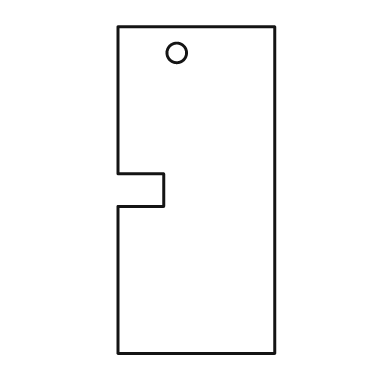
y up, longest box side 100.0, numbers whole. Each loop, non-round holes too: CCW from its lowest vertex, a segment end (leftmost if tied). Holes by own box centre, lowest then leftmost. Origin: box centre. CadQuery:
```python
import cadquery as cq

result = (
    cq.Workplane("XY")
    .moveTo(-24.0, -50.0)
    .lineTo(24.0, -50.0)
    .lineTo(24.0, 50.0)
    .lineTo(-24.0, 50.0)
    .lineTo(-24.0, 5.0)
    .lineTo(-10.0, 5.0)
    .lineTo(-10.0, -5.0)
    .lineTo(-24.0, -5.0)
    .close()
    .moveTo(-6.0, 42.0)
    .circle(3.0)
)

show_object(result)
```